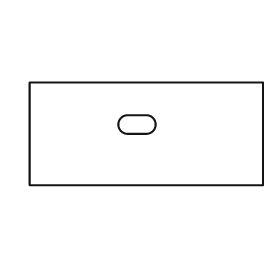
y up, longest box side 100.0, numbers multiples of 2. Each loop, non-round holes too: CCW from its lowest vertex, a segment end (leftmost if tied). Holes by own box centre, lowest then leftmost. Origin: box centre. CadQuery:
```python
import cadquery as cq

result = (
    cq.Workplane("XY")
    .moveTo(-50.0, -22.0)
    .lineTo(50.0, -22.0)
    .lineTo(50.0, 22.0)
    .lineTo(-50.0, 22.0)
    .close()
    .moveTo(-8.0, 0.0)
    .lineTo(0.0, 0.0)
    .threePointArc((4.0, 4.0), (0.0, 8.0))
    .lineTo(-8.0, 8.0)
    .threePointArc((-12.0, 4.0), (-8.0, 0.0))
    .close()
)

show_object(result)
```